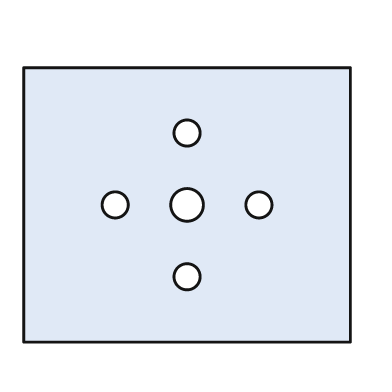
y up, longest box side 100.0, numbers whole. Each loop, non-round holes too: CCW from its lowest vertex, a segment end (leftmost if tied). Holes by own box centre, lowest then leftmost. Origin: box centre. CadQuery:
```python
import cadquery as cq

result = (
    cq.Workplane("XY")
    .moveTo(-50.0, -42.0)
    .lineTo(50.0, -42.0)
    .lineTo(50.0, 42.0)
    .lineTo(-50.0, 42.0)
    .close()
    .moveTo(0.0, -22.0)
    .circle(4.0)
    .moveTo(-22.0, 0.0)
    .circle(4.0)
    .moveTo(0.0, 0.0)
    .circle(5.0)
    .moveTo(22.0, 0.0)
    .circle(4.0)
    .moveTo(0.0, 22.0)
    .circle(4.0)
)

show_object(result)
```